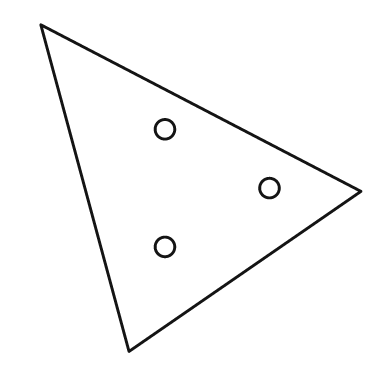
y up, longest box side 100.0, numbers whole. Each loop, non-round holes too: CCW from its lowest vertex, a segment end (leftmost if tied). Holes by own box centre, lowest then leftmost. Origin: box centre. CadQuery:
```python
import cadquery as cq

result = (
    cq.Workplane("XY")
    .moveTo(-22.0, -50.0)
    .lineTo(49.0, -1.0)
    .lineTo(-49.0, 50.0)
    .close()
    .moveTo(-11.0, -18.0)
    .circle(3.0)
    .moveTo(21.0, 0.0)
    .circle(3.0)
    .moveTo(-11.0, 18.0)
    .circle(3.0)
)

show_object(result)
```